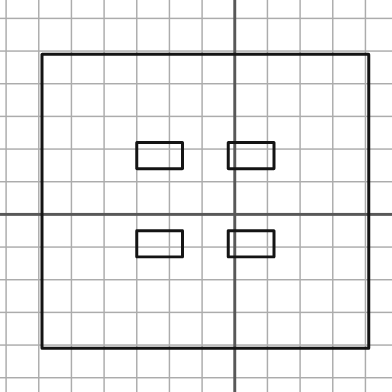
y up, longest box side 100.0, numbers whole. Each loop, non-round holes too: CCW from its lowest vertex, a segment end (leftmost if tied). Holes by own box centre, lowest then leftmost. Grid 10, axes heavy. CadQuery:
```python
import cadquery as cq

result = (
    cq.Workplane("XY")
    .moveTo(-59.0, -41.0)
    .lineTo(41.0, -41.0)
    .lineTo(41.0, 49.0)
    .lineTo(-59.0, 49.0)
    .close()
    .moveTo(-30.0, -13.0)
    .lineTo(-16.0, -13.0)
    .lineTo(-16.0, -5.0)
    .lineTo(-30.0, -5.0)
    .close()
    .moveTo(-2.0, -13.0)
    .lineTo(12.0, -13.0)
    .lineTo(12.0, -5.0)
    .lineTo(-2.0, -5.0)
    .close()
    .moveTo(-30.0, 14.0)
    .lineTo(-16.0, 14.0)
    .lineTo(-16.0, 22.0)
    .lineTo(-30.0, 22.0)
    .close()
    .moveTo(-2.0, 14.0)
    .lineTo(12.0, 14.0)
    .lineTo(12.0, 22.0)
    .lineTo(-2.0, 22.0)
    .close()
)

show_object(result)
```